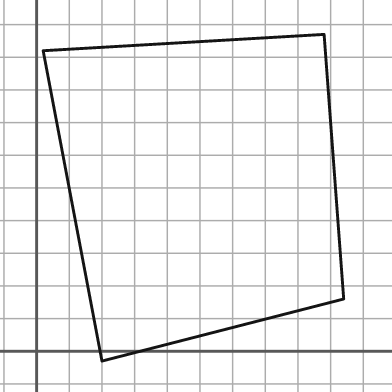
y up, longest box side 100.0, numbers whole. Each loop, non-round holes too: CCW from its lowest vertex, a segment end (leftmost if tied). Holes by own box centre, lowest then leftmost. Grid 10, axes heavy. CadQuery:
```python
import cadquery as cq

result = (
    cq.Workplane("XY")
    .moveTo(20.0, -3.0)
    .lineTo(94.0, 16.0)
    .lineTo(88.0, 97.0)
    .lineTo(2.0, 92.0)
    .close()
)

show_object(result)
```